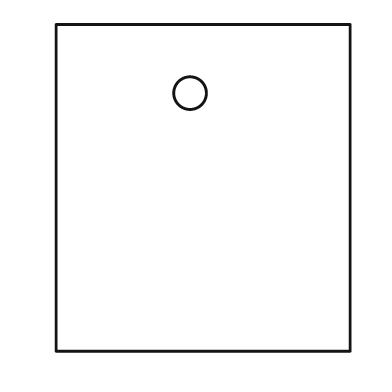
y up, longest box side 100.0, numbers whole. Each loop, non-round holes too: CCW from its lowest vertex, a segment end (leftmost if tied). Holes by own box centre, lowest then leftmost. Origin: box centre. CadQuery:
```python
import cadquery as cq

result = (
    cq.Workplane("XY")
    .moveTo(-45.0, -50.0)
    .lineTo(45.0, -50.0)
    .lineTo(45.0, 50.0)
    .lineTo(-45.0, 50.0)
    .close()
    .moveTo(-4.0, 29.0)
    .circle(5.0)
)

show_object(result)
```